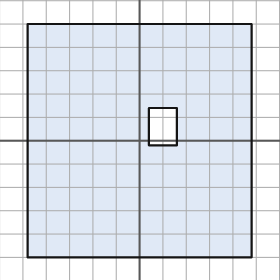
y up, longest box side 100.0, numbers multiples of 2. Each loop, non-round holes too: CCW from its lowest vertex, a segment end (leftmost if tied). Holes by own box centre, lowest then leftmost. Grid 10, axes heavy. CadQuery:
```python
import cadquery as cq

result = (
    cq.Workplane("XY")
    .moveTo(-48.0, -50.0)
    .lineTo(48.0, -50.0)
    .lineTo(48.0, 50.0)
    .lineTo(-48.0, 50.0)
    .close()
    .moveTo(4.0, -2.0)
    .lineTo(16.0, -2.0)
    .lineTo(16.0, 14.0)
    .lineTo(4.0, 14.0)
    .close()
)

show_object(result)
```